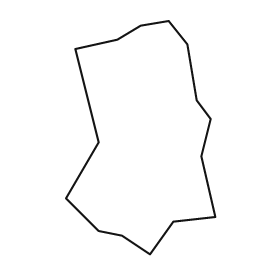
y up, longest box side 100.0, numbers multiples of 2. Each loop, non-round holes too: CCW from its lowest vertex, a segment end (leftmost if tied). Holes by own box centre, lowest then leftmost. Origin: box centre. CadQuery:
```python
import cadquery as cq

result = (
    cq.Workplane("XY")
    .moveTo(4.0, -50.0)
    .lineTo(14.0, -36.0)
    .lineTo(32.0, -34.0)
    .lineTo(26.0, -8.0)
    .lineTo(30.0, 8.0)
    .lineTo(24.0, 16.0)
    .lineTo(20.0, 40.0)
    .lineTo(12.0, 50.0)
    .lineTo(0.0, 48.0)
    .lineTo(-10.0, 42.0)
    .lineTo(-28.0, 38.0)
    .lineTo(-18.0, -2.0)
    .lineTo(-32.0, -26.0)
    .lineTo(-18.0, -40.0)
    .lineTo(-8.0, -42.0)
    .close()
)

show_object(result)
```